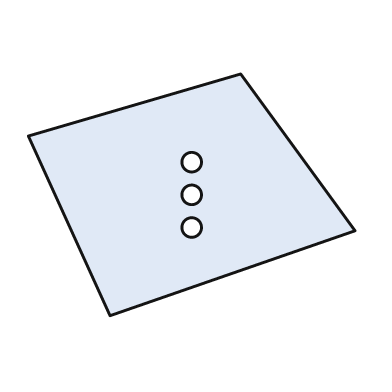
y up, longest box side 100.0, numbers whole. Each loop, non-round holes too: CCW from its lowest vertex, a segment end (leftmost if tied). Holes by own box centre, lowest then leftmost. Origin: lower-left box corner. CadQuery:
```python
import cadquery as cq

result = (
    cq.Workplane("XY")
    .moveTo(25.0, 0.0)
    .lineTo(100.0, 26.0)
    .lineTo(65.0, 74.0)
    .lineTo(0.0, 55.0)
    .close()
    .moveTo(50.0, 27.0)
    .circle(3.0)
    .moveTo(50.0, 37.0)
    .circle(3.0)
    .moveTo(50.0, 47.0)
    .circle(3.0)
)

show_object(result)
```